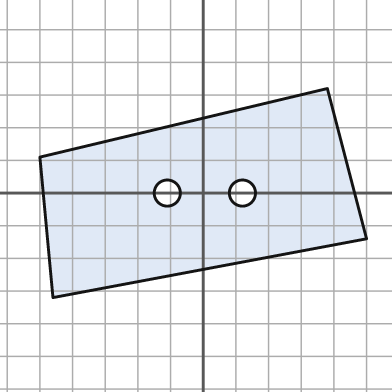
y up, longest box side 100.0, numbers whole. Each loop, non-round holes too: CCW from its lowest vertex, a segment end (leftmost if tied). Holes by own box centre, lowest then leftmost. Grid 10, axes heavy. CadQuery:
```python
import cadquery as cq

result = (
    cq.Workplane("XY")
    .moveTo(-46.0, -32.0)
    .lineTo(50.0, -14.0)
    .lineTo(38.0, 32.0)
    .lineTo(-50.0, 11.0)
    .close()
    .moveTo(-11.0, 0.0)
    .circle(4.0)
    .moveTo(12.0, 0.0)
    .circle(4.0)
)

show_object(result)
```